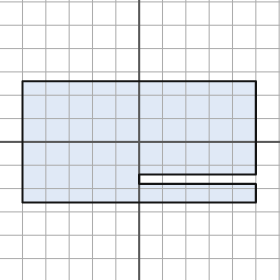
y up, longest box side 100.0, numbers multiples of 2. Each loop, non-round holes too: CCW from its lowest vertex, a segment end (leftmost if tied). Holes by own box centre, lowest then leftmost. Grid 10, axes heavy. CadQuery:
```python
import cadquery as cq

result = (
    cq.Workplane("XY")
    .moveTo(-50.0, -26.0)
    .lineTo(50.0, -26.0)
    .lineTo(50.0, -18.0)
    .lineTo(0.0, -18.0)
    .lineTo(0.0, -14.0)
    .lineTo(50.0, -14.0)
    .lineTo(50.0, 26.0)
    .lineTo(-50.0, 26.0)
    .close()
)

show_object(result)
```